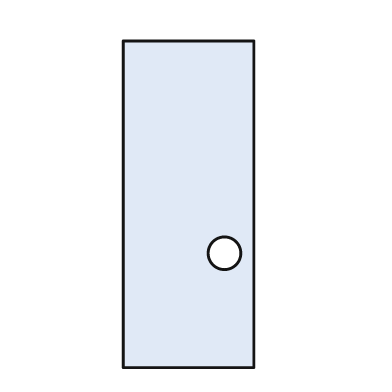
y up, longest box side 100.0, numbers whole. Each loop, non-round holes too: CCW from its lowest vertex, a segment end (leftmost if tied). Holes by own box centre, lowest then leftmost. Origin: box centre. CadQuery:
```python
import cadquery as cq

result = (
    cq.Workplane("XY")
    .moveTo(-20.0, -50.0)
    .lineTo(20.0, -50.0)
    .lineTo(20.0, 50.0)
    .lineTo(-20.0, 50.0)
    .close()
    .moveTo(11.0, -15.0)
    .circle(5.0)
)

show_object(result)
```